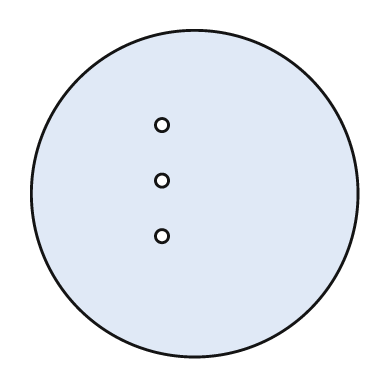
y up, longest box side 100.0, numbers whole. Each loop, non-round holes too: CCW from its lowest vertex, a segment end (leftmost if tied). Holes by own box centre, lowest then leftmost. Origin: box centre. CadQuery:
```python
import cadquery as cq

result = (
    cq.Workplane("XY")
    .moveTo(0.0, 0.0)
    .circle(50.0)
    .moveTo(-10.0, -13.0)
    .circle(2.0)
    .moveTo(-10.0, 4.0)
    .circle(2.0)
    .moveTo(-10.0, 21.0)
    .circle(2.0)
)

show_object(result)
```